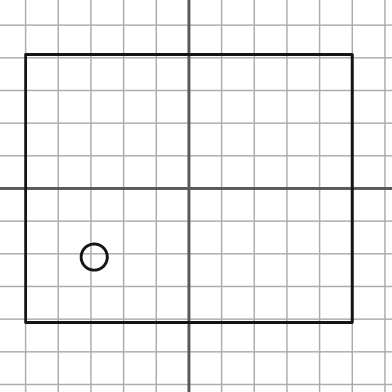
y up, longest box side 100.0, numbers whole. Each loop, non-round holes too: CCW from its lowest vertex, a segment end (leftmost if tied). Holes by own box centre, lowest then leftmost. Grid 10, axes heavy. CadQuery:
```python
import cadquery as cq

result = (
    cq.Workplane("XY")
    .moveTo(-50.0, -41.0)
    .lineTo(50.0, -41.0)
    .lineTo(50.0, 41.0)
    .lineTo(-50.0, 41.0)
    .close()
    .moveTo(-29.0, -21.0)
    .circle(4.0)
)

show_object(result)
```